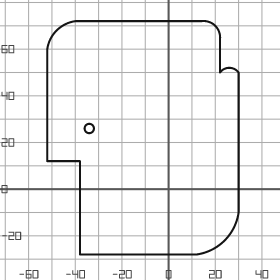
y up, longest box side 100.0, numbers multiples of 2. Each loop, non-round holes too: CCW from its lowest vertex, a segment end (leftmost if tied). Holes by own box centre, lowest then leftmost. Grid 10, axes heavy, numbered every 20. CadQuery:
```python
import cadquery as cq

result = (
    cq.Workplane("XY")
    .moveTo(-38.0, -28.0)
    .lineTo(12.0, -28.0)
    .threePointArc((24.0, -22.0), (30.0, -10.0))
    .lineTo(30.0, 50.0)
    .threePointArc((26.0, 52.0), (22.0, 50.0))
    .lineTo(22.0, 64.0)
    .threePointArc((20.0, 70.0), (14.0, 72.0))
    .lineTo(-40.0, 72.0)
    .threePointArc((-48.0, 68.0), (-52.0, 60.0))
    .lineTo(-52.0, 12.0)
    .lineTo(-38.0, 12.0)
    .close()
    .moveTo(-34.0, 26.0)
    .circle(2.0)
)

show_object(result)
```